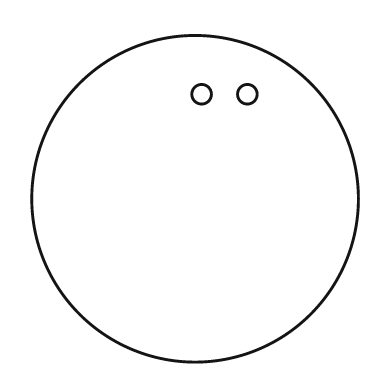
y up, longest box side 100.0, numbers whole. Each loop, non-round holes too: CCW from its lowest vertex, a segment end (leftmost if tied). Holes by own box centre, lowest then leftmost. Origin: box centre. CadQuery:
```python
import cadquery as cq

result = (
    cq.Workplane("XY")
    .moveTo(0.0, 0.0)
    .circle(50.0)
    .moveTo(2.0, 32.0)
    .circle(3.0)
    .moveTo(16.0, 32.0)
    .circle(3.0)
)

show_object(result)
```